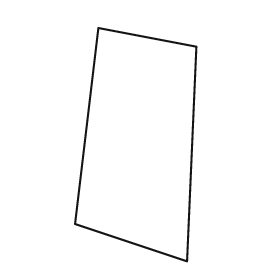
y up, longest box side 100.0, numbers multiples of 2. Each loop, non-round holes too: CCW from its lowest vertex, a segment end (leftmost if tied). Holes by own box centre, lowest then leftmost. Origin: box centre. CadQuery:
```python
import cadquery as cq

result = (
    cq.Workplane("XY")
    .moveTo(22.0, -50.0)
    .lineTo(26.0, 42.0)
    .lineTo(-16.0, 50.0)
    .lineTo(-26.0, -34.0)
    .close()
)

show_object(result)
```